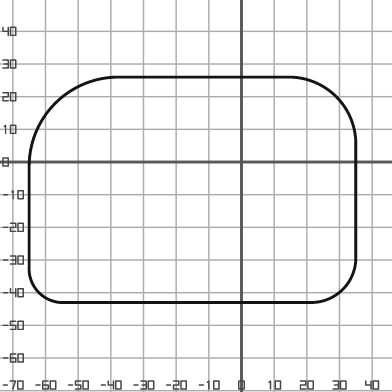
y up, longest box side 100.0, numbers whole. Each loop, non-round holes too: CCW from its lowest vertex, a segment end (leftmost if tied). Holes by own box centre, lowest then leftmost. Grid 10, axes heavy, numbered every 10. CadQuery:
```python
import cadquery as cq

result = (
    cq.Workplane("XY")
    .moveTo(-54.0, -43.0)
    .lineTo(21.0, -43.0)
    .threePointArc((31.0, -39.0), (35.0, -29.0))
    .lineTo(35.0, 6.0)
    .threePointArc((29.0, 20.0), (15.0, 26.0))
    .lineTo(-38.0, 26.0)
    .threePointArc((-57.0, 18.0), (-65.0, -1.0))
    .lineTo(-65.0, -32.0)
    .threePointArc((-62.0, -40.0), (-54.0, -43.0))
    .close()
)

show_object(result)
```